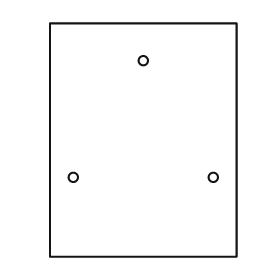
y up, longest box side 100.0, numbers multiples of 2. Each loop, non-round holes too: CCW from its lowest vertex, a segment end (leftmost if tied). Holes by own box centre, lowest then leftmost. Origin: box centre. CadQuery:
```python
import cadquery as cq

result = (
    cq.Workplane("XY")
    .moveTo(-40.0, -50.0)
    .lineTo(40.0, -50.0)
    .lineTo(40.0, 50.0)
    .lineTo(-40.0, 50.0)
    .close()
    .moveTo(-30.0, -16.0)
    .circle(2.0)
    .moveTo(30.0, -16.0)
    .circle(2.0)
    .moveTo(0.0, 34.0)
    .circle(2.0)
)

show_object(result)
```